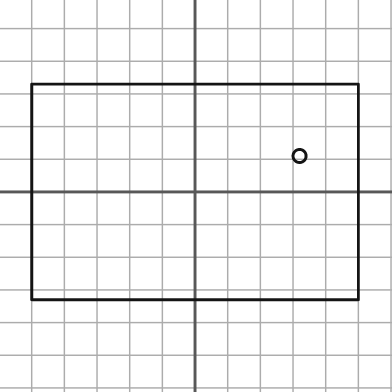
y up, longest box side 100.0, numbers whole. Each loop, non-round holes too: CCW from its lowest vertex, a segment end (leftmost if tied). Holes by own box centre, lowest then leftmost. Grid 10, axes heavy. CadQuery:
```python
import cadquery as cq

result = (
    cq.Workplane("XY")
    .moveTo(-50.0, -33.0)
    .lineTo(50.0, -33.0)
    .lineTo(50.0, 33.0)
    .lineTo(-50.0, 33.0)
    .close()
    .moveTo(32.0, 11.0)
    .circle(2.0)
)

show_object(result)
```